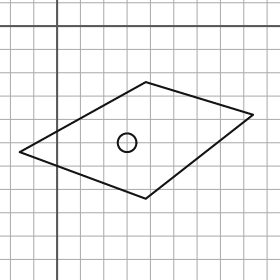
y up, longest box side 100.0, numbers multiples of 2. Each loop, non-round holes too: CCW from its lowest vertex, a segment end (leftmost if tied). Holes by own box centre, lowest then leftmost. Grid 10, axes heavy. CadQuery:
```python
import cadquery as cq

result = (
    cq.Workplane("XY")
    .moveTo(38.0, -74.0)
    .lineTo(84.0, -38.0)
    .lineTo(38.0, -24.0)
    .lineTo(-16.0, -54.0)
    .close()
    .moveTo(30.0, -50.0)
    .circle(4.0)
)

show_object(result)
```